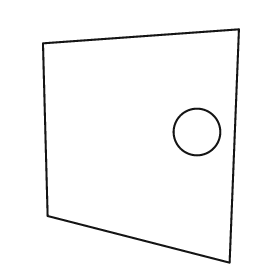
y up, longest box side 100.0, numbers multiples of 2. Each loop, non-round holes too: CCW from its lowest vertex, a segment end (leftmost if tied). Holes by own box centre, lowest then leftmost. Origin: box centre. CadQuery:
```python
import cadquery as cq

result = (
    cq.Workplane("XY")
    .moveTo(38.0, -50.0)
    .lineTo(42.0, 50.0)
    .lineTo(-42.0, 44.0)
    .lineTo(-40.0, -30.0)
    .close()
    .moveTo(24.0, 6.0)
    .circle(10.0)
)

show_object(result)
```